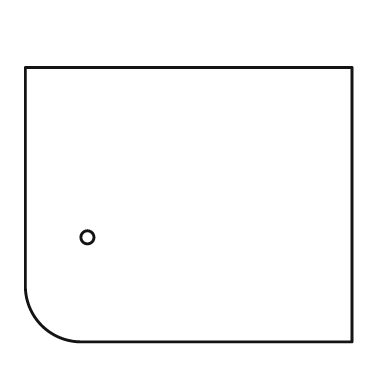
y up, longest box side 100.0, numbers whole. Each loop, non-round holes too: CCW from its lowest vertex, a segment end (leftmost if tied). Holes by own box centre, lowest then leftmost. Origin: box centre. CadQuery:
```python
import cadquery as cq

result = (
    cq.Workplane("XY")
    .moveTo(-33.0, -42.0)
    .lineTo(50.0, -42.0)
    .lineTo(50.0, 42.0)
    .lineTo(-50.0, 42.0)
    .lineTo(-50.0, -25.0)
    .threePointArc((-45.0, -37.0), (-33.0, -42.0))
    .close()
    .moveTo(-31.0, -10.0)
    .circle(2.0)
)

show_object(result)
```